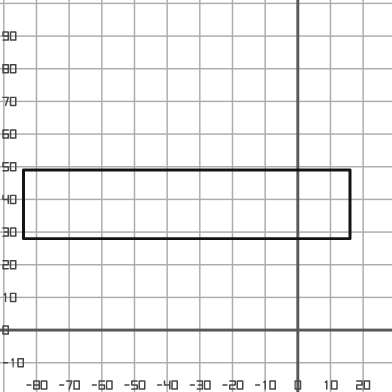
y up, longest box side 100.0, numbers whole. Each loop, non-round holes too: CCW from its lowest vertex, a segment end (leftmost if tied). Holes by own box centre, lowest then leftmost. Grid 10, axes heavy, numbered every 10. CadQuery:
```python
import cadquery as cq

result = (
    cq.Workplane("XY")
    .moveTo(-84.0, 28.0)
    .lineTo(16.0, 28.0)
    .lineTo(16.0, 49.0)
    .lineTo(-84.0, 49.0)
    .close()
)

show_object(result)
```